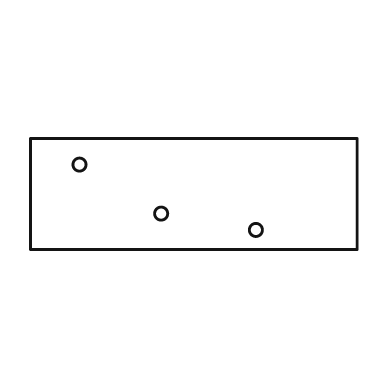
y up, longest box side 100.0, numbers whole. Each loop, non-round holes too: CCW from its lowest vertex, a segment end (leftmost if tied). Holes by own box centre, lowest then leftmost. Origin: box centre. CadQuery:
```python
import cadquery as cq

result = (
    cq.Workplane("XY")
    .moveTo(-50.0, -17.0)
    .lineTo(50.0, -17.0)
    .lineTo(50.0, 17.0)
    .lineTo(-50.0, 17.0)
    .close()
    .moveTo(19.0, -11.0)
    .circle(2.0)
    .moveTo(-10.0, -6.0)
    .circle(2.0)
    .moveTo(-35.0, 9.0)
    .circle(2.0)
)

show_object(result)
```